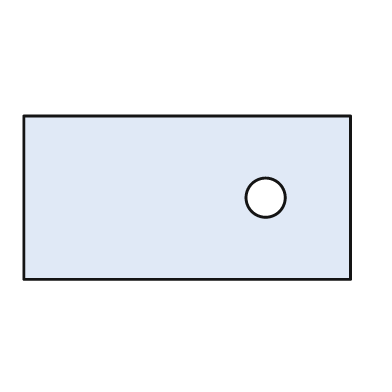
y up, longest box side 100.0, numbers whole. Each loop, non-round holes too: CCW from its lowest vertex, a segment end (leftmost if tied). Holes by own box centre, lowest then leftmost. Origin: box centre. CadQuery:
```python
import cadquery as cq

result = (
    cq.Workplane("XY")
    .moveTo(-50.0, -25.0)
    .lineTo(50.0, -25.0)
    .lineTo(50.0, 25.0)
    .lineTo(-50.0, 25.0)
    .close()
    .moveTo(24.0, 0.0)
    .circle(6.0)
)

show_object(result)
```